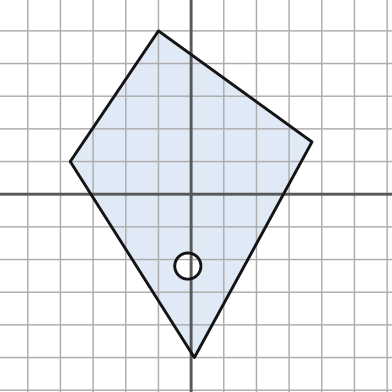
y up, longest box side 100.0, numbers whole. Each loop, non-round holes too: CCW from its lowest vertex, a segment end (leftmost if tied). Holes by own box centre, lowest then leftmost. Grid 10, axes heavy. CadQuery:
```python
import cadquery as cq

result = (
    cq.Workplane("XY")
    .moveTo(1.0, -50.0)
    .lineTo(37.0, 16.0)
    .lineTo(-10.0, 50.0)
    .lineTo(-37.0, 10.0)
    .close()
    .moveTo(-1.0, -22.0)
    .circle(4.0)
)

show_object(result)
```